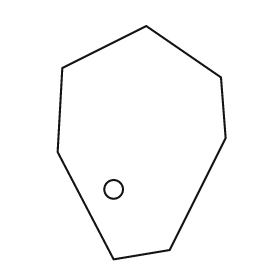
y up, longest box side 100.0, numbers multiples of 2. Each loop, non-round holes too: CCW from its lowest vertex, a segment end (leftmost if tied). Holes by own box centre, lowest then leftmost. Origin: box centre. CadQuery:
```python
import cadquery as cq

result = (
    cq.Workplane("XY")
    .moveTo(-12.0, -50.0)
    .lineTo(12.0, -46.0)
    .lineTo(36.0, 2.0)
    .lineTo(34.0, 28.0)
    .lineTo(2.0, 50.0)
    .lineTo(-34.0, 32.0)
    .lineTo(-36.0, -4.0)
    .close()
    .moveTo(-12.0, -20.0)
    .circle(4.0)
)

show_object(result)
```